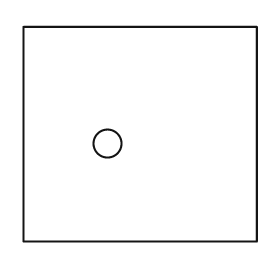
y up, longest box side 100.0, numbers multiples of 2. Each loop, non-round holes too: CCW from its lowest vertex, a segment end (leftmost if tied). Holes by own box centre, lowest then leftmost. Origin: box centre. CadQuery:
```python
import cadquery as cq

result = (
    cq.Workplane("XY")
    .moveTo(-50.0, -46.0)
    .lineTo(50.0, -46.0)
    .lineTo(50.0, 46.0)
    .lineTo(-50.0, 46.0)
    .close()
    .moveTo(-14.0, -4.0)
    .circle(6.0)
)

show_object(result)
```